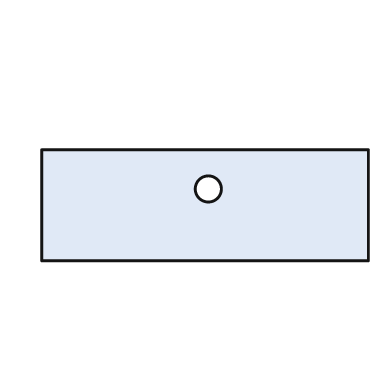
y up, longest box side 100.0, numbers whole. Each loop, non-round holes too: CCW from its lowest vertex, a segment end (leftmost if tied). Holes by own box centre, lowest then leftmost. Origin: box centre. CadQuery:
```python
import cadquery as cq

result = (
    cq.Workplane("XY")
    .moveTo(-50.0, -17.0)
    .lineTo(50.0, -17.0)
    .lineTo(50.0, 17.0)
    .lineTo(-50.0, 17.0)
    .close()
    .moveTo(1.0, 5.0)
    .circle(4.0)
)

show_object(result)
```